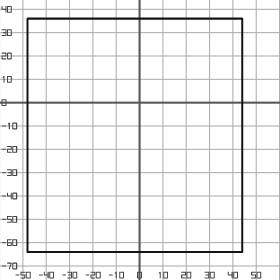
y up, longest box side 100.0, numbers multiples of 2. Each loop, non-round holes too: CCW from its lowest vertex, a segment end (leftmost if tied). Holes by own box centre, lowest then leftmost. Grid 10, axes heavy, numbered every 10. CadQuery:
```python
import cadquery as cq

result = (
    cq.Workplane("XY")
    .moveTo(-48.0, -64.0)
    .lineTo(44.0, -64.0)
    .lineTo(44.0, 36.0)
    .lineTo(-48.0, 36.0)
    .close()
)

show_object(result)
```